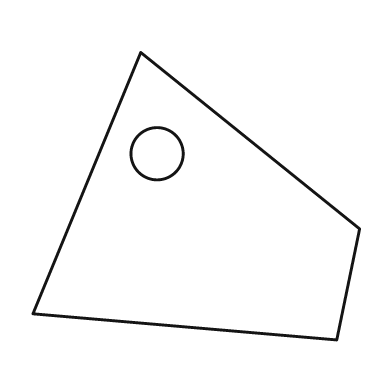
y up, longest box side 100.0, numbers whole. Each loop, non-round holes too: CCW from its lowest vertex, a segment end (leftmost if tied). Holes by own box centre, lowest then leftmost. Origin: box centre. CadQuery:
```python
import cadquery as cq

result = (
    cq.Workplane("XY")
    .moveTo(43.0, -44.0)
    .lineTo(50.0, -10.0)
    .lineTo(-17.0, 44.0)
    .lineTo(-50.0, -36.0)
    .close()
    .moveTo(-12.0, 13.0)
    .circle(8.0)
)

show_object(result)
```